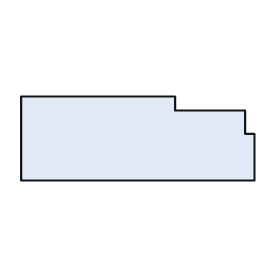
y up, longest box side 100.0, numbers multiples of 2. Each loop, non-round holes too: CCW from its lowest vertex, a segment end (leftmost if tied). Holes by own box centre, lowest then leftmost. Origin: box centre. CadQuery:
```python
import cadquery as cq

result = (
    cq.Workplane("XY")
    .moveTo(-50.0, -18.0)
    .lineTo(50.0, -18.0)
    .lineTo(50.0, 2.0)
    .lineTo(46.0, 2.0)
    .lineTo(46.0, 12.0)
    .lineTo(16.0, 12.0)
    .lineTo(16.0, 18.0)
    .lineTo(-50.0, 18.0)
    .close()
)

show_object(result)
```